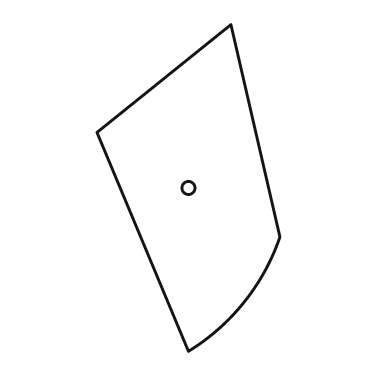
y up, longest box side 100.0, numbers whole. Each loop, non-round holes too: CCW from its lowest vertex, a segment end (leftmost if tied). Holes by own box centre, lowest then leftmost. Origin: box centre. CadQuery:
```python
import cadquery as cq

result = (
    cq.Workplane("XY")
    .moveTo(0.0, -50.0)
    .threePointArc((17.0, -35.0), (28.0, -15.0))
    .lineTo(13.0, 50.0)
    .lineTo(-28.0, 17.0)
    .close()
    .moveTo(0.0, 0.0)
    .circle(2.0)
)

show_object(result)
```